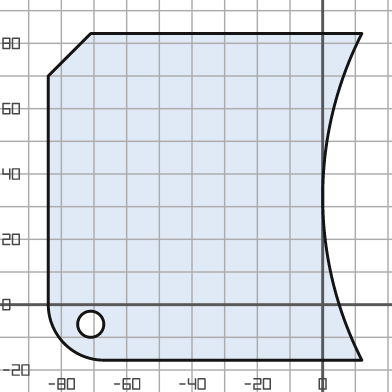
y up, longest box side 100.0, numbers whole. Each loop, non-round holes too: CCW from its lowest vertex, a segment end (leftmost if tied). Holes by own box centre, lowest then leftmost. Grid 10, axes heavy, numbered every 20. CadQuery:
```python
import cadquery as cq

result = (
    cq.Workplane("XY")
    .moveTo(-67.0, -17.0)
    .lineTo(12.0, -17.0)
    .threePointArc((0.0, 33.0), (12.0, 83.0))
    .lineTo(-71.0, 83.0)
    .lineTo(-84.0, 70.0)
    .lineTo(-84.0, 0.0)
    .threePointArc((-79.0, -12.0), (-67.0, -17.0))
    .close()
    .moveTo(-71.0, -6.0)
    .circle(4.0)
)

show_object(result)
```